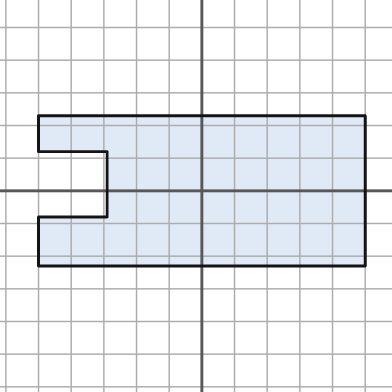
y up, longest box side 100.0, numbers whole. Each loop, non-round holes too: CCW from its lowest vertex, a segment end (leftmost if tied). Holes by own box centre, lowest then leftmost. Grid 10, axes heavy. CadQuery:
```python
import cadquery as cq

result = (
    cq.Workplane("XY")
    .moveTo(-50.0, -23.0)
    .lineTo(50.0, -23.0)
    .lineTo(50.0, 23.0)
    .lineTo(-50.0, 23.0)
    .lineTo(-50.0, 12.0)
    .lineTo(-29.0, 12.0)
    .lineTo(-29.0, -8.0)
    .lineTo(-50.0, -8.0)
    .close()
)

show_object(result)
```